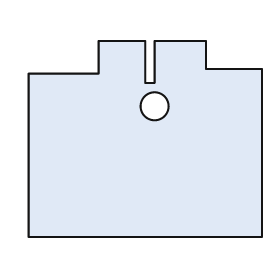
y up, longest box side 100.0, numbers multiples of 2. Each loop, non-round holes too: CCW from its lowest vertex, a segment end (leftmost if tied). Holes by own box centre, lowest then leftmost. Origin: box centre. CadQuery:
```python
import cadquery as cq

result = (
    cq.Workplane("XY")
    .moveTo(-50.0, -42.0)
    .lineTo(50.0, -42.0)
    .lineTo(50.0, 30.0)
    .lineTo(26.0, 30.0)
    .lineTo(26.0, 42.0)
    .lineTo(4.0, 42.0)
    .lineTo(4.0, 24.0)
    .lineTo(0.0, 24.0)
    .lineTo(0.0, 42.0)
    .lineTo(-20.0, 42.0)
    .lineTo(-20.0, 28.0)
    .lineTo(-50.0, 28.0)
    .close()
    .moveTo(4.0, 14.0)
    .circle(6.0)
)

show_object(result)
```